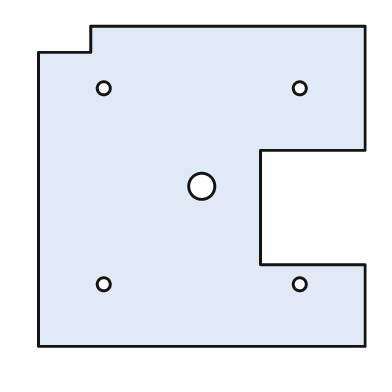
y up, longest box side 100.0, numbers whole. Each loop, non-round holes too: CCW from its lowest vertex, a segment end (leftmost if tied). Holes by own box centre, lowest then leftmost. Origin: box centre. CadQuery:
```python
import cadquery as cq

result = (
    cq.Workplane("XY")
    .moveTo(-50.0, -49.0)
    .lineTo(50.0, -49.0)
    .lineTo(50.0, -24.0)
    .lineTo(18.0, -24.0)
    .lineTo(18.0, 11.0)
    .lineTo(50.0, 11.0)
    .lineTo(50.0, 49.0)
    .lineTo(-34.0, 49.0)
    .lineTo(-34.0, 41.0)
    .lineTo(-50.0, 41.0)
    .close()
    .moveTo(-30.0, -30.0)
    .circle(2.0)
    .moveTo(30.0, -30.0)
    .circle(2.0)
    .moveTo(0.0, 0.0)
    .circle(4.0)
    .moveTo(-30.0, 30.0)
    .circle(2.0)
    .moveTo(30.0, 30.0)
    .circle(2.0)
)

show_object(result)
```